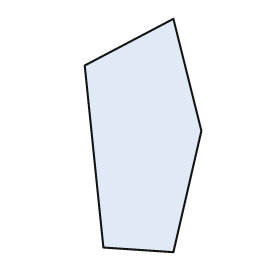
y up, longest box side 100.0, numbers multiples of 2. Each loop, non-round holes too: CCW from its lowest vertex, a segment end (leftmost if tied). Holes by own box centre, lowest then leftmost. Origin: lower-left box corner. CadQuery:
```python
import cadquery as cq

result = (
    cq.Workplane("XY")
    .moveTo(38.0, 0.0)
    .lineTo(50.0, 52.0)
    .lineTo(38.0, 100.0)
    .lineTo(0.0, 80.0)
    .lineTo(8.0, 2.0)
    .close()
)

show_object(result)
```